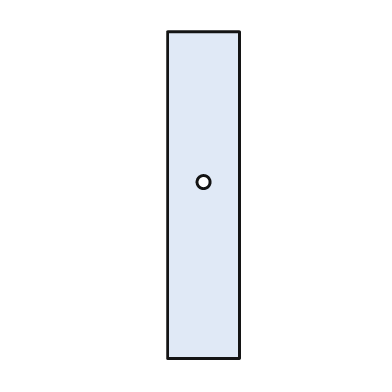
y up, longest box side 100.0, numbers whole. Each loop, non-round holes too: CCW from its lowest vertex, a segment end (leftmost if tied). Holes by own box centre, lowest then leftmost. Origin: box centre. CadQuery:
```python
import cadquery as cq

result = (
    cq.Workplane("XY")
    .moveTo(-11.0, -50.0)
    .lineTo(11.0, -50.0)
    .lineTo(11.0, 50.0)
    .lineTo(-11.0, 50.0)
    .close()
    .moveTo(0.0, 4.0)
    .circle(2.0)
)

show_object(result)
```